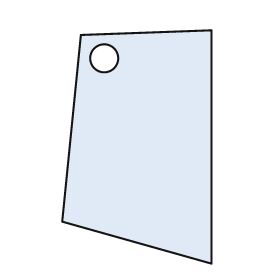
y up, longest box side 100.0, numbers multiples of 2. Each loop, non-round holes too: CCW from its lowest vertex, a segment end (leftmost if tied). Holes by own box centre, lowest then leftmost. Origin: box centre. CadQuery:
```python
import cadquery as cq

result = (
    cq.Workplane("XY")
    .moveTo(32.0, -50.0)
    .lineTo(32.0, 50.0)
    .lineTo(-24.0, 48.0)
    .lineTo(-32.0, -32.0)
    .close()
    .moveTo(-14.0, 38.0)
    .circle(6.0)
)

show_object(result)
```